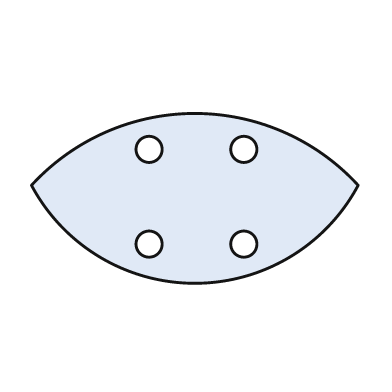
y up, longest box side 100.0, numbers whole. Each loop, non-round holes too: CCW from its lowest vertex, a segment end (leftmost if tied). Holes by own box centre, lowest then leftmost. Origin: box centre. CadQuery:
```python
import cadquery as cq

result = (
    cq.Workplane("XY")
    .moveTo(-50.0, 4.0)
    .threePointArc((0.0, -26.0), (50.0, 4.0))
    .threePointArc((0.0, 26.0), (-50.0, 4.0))
    .close()
    .moveTo(-14.0, -14.0)
    .circle(4.0)
    .moveTo(15.0, -14.0)
    .circle(4.0)
    .moveTo(-14.0, 15.0)
    .circle(4.0)
    .moveTo(15.0, 15.0)
    .circle(4.0)
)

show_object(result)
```